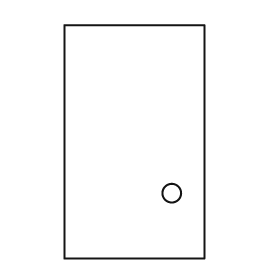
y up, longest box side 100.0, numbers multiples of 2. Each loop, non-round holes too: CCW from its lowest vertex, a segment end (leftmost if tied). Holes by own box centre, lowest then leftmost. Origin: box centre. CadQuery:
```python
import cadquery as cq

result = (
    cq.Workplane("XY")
    .moveTo(-30.0, -50.0)
    .lineTo(30.0, -50.0)
    .lineTo(30.0, 50.0)
    .lineTo(-30.0, 50.0)
    .close()
    .moveTo(16.0, -22.0)
    .circle(4.0)
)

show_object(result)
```